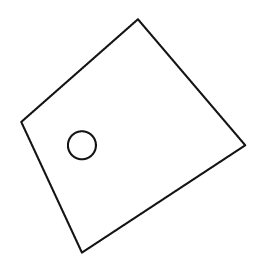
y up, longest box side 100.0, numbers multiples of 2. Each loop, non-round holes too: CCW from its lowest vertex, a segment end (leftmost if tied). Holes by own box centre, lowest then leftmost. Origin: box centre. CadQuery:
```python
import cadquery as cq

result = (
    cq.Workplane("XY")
    .moveTo(-22.0, -50.0)
    .lineTo(48.0, -4.0)
    .lineTo(2.0, 50.0)
    .lineTo(-48.0, 6.0)
    .close()
    .moveTo(-22.0, -4.0)
    .circle(6.0)
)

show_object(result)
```